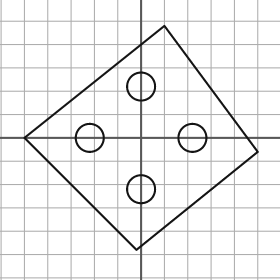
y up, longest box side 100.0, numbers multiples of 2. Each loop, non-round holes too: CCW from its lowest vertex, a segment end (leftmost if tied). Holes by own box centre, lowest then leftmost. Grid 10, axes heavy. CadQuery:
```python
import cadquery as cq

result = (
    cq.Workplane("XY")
    .moveTo(-2.0, -48.0)
    .lineTo(50.0, -6.0)
    .lineTo(10.0, 48.0)
    .lineTo(-50.0, 0.0)
    .close()
    .moveTo(0.0, -22.0)
    .circle(6.0)
    .moveTo(-22.0, 0.0)
    .circle(6.0)
    .moveTo(22.0, 0.0)
    .circle(6.0)
    .moveTo(0.0, 22.0)
    .circle(6.0)
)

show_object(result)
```